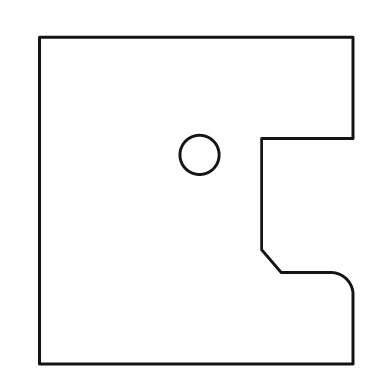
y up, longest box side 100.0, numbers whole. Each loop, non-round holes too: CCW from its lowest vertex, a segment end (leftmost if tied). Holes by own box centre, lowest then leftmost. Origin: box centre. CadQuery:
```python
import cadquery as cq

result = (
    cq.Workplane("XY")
    .moveTo(-48.0, -50.0)
    .lineTo(48.0, -50.0)
    .lineTo(48.0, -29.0)
    .threePointArc((46.0, -24.0), (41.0, -22.0))
    .lineTo(26.0, -22.0)
    .lineTo(20.0, -15.0)
    .lineTo(20.0, 19.0)
    .lineTo(48.0, 19.0)
    .lineTo(48.0, 50.0)
    .lineTo(-48.0, 50.0)
    .close()
    .moveTo(1.0, 14.0)
    .circle(6.0)
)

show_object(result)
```